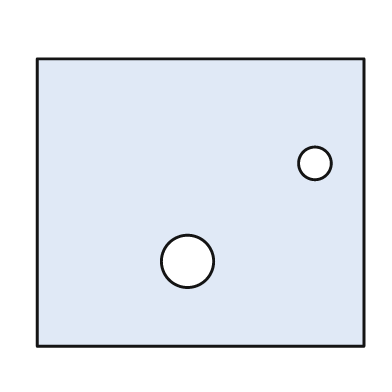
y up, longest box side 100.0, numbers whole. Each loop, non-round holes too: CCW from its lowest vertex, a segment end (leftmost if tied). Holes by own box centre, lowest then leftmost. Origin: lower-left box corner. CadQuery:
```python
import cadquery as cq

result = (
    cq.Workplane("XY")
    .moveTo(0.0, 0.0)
    .lineTo(100.0, 0.0)
    .lineTo(100.0, 88.0)
    .lineTo(0.0, 88.0)
    .close()
    .moveTo(46.0, 26.0)
    .circle(8.0)
    .moveTo(85.0, 56.0)
    .circle(5.0)
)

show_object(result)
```